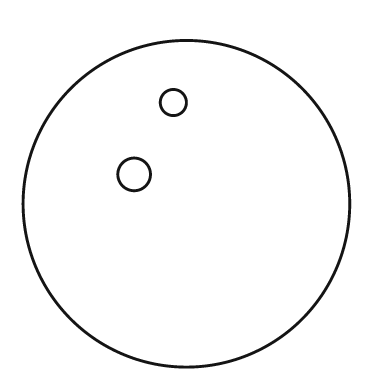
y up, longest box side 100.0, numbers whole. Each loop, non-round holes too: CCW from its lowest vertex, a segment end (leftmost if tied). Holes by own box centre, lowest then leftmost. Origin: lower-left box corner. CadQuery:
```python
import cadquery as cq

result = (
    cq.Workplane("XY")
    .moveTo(50.0, 50.0)
    .circle(50.0)
    .moveTo(34.0, 59.0)
    .circle(5.0)
    .moveTo(46.0, 81.0)
    .circle(4.0)
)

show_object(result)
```